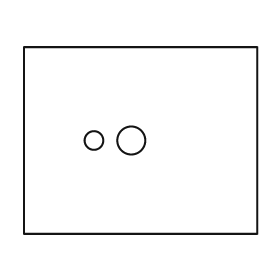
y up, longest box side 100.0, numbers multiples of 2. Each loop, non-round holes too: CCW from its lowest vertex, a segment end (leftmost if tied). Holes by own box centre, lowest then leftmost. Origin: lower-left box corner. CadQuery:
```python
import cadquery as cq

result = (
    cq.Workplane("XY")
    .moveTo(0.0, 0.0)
    .lineTo(100.0, 0.0)
    .lineTo(100.0, 80.0)
    .lineTo(0.0, 80.0)
    .close()
    .moveTo(30.0, 40.0)
    .circle(4.0)
    .moveTo(46.0, 40.0)
    .circle(6.0)
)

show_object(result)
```